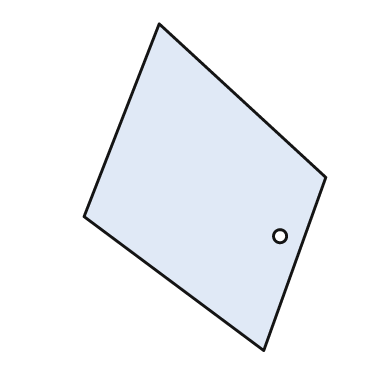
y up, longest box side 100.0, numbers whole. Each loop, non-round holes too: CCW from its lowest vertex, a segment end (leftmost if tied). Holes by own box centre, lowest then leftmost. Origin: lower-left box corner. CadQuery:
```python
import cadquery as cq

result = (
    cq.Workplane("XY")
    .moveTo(55.0, 0.0)
    .lineTo(74.0, 53.0)
    .lineTo(23.0, 100.0)
    .lineTo(0.0, 41.0)
    .close()
    .moveTo(60.0, 35.0)
    .circle(2.0)
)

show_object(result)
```